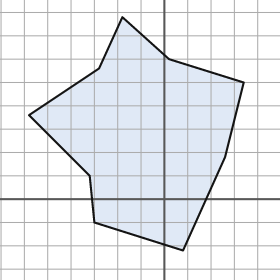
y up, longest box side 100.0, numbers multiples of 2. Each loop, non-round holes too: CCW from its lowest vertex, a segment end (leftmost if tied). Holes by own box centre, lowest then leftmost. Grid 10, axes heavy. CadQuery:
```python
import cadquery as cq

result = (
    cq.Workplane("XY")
    .moveTo(8.0, -22.0)
    .lineTo(26.0, 18.0)
    .lineTo(34.0, 50.0)
    .lineTo(2.0, 60.0)
    .lineTo(-18.0, 78.0)
    .lineTo(-28.0, 56.0)
    .lineTo(-58.0, 36.0)
    .lineTo(-32.0, 10.0)
    .lineTo(-30.0, -10.0)
    .close()
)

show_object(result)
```